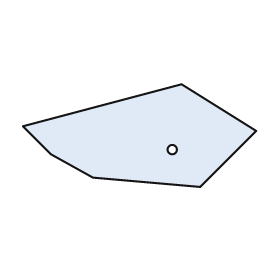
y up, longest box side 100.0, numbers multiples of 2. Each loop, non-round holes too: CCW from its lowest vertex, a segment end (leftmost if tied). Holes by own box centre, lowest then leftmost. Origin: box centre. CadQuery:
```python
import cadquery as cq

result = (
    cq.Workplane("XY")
    .moveTo(26.0, -22.0)
    .lineTo(50.0, 2.0)
    .lineTo(18.0, 22.0)
    .lineTo(-50.0, 4.0)
    .lineTo(-38.0, -8.0)
    .lineTo(-20.0, -18.0)
    .close()
    .moveTo(14.0, -6.0)
    .circle(2.0)
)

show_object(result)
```